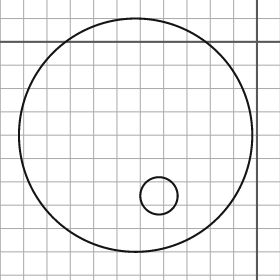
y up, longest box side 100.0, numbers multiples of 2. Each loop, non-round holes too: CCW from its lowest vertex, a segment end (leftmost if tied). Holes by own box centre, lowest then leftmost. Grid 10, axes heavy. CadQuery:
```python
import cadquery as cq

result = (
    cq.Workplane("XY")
    .moveTo(-52.0, -40.0)
    .circle(50.0)
    .moveTo(-42.0, -66.0)
    .circle(8.0)
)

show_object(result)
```